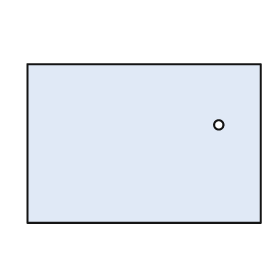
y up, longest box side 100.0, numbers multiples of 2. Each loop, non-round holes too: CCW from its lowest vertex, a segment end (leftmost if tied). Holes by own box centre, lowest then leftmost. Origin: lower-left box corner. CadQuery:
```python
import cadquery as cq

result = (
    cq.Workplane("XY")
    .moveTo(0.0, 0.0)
    .lineTo(100.0, 0.0)
    .lineTo(100.0, 68.0)
    .lineTo(0.0, 68.0)
    .close()
    .moveTo(82.0, 42.0)
    .circle(2.0)
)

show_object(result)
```